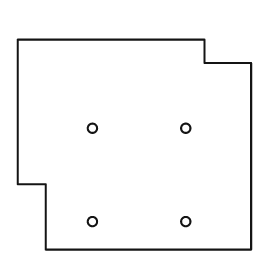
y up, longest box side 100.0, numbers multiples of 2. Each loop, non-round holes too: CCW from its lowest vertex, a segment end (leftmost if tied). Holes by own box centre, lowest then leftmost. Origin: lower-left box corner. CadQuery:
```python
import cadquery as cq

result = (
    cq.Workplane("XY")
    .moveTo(12.0, 0.0)
    .lineTo(100.0, 0.0)
    .lineTo(100.0, 80.0)
    .lineTo(80.0, 80.0)
    .lineTo(80.0, 90.0)
    .lineTo(0.0, 90.0)
    .lineTo(0.0, 28.0)
    .lineTo(12.0, 28.0)
    .close()
    .moveTo(32.0, 12.0)
    .circle(2.0)
    .moveTo(72.0, 12.0)
    .circle(2.0)
    .moveTo(32.0, 52.0)
    .circle(2.0)
    .moveTo(72.0, 52.0)
    .circle(2.0)
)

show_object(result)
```